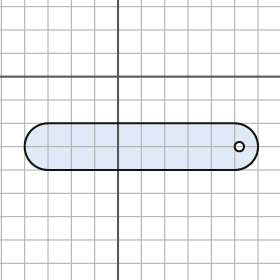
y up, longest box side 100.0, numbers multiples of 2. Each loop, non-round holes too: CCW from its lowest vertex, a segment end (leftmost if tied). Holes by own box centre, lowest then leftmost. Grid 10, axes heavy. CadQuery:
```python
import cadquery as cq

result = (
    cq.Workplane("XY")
    .moveTo(-30.0, -40.0)
    .lineTo(50.0, -40.0)
    .threePointArc((60.0, -30.0), (50.0, -20.0))
    .lineTo(-30.0, -20.0)
    .threePointArc((-40.0, -30.0), (-30.0, -40.0))
    .close()
    .moveTo(52.0, -30.0)
    .circle(2.0)
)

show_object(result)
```